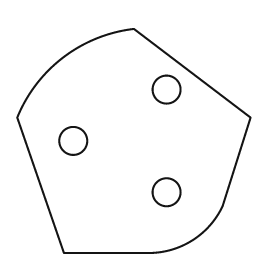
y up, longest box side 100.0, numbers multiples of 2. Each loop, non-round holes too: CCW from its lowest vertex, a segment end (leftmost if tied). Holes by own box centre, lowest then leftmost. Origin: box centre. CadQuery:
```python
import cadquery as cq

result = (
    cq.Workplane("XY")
    .moveTo(-30.0, -48.0)
    .lineTo(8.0, -48.0)
    .threePointArc((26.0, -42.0), (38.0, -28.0))
    .lineTo(50.0, 10.0)
    .lineTo(0.0, 48.0)
    .threePointArc((-30.0, 36.0), (-50.0, 10.0))
    .close()
    .moveTo(14.0, -22.0)
    .circle(6.0)
    .moveTo(-26.0, 0.0)
    .circle(6.0)
    .moveTo(14.0, 22.0)
    .circle(6.0)
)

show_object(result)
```